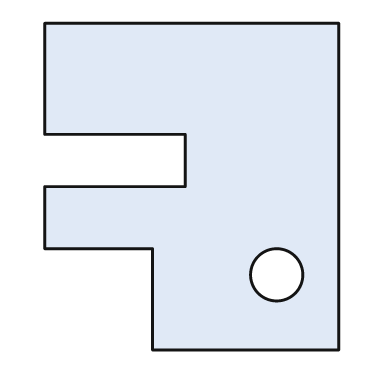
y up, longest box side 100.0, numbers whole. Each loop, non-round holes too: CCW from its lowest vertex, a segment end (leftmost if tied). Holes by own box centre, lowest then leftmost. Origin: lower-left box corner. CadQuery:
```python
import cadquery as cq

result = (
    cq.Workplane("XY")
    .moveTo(33.0, 0.0)
    .lineTo(90.0, 0.0)
    .lineTo(90.0, 100.0)
    .lineTo(0.0, 100.0)
    .lineTo(0.0, 66.0)
    .lineTo(43.0, 66.0)
    .lineTo(43.0, 50.0)
    .lineTo(0.0, 50.0)
    .lineTo(0.0, 31.0)
    .lineTo(33.0, 31.0)
    .close()
    .moveTo(71.0, 23.0)
    .circle(8.0)
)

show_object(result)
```